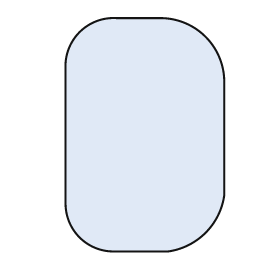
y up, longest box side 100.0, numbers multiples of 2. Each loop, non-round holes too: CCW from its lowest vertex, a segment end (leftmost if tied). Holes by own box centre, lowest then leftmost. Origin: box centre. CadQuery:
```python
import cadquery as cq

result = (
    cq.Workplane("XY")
    .moveTo(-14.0, -50.0)
    .lineTo(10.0, -50.0)
    .threePointArc((26.0, -42.0), (34.0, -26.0))
    .lineTo(34.0, 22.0)
    .threePointArc((26.0, 42.0), (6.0, 50.0))
    .lineTo(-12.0, 50.0)
    .threePointArc((-28.0, 44.0), (-34.0, 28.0))
    .lineTo(-34.0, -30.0)
    .threePointArc((-28.0, -44.0), (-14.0, -50.0))
    .close()
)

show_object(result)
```